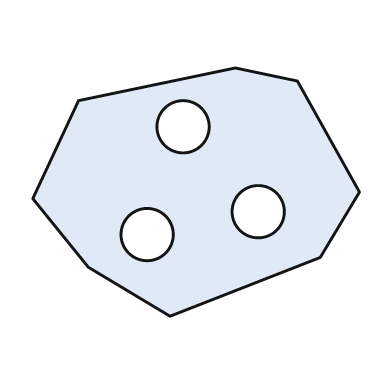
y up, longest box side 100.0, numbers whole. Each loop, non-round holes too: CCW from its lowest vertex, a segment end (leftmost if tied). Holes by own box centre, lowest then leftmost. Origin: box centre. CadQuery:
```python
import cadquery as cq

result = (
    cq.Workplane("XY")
    .moveTo(-8.0, -38.0)
    .lineTo(38.0, -20.0)
    .lineTo(50.0, 0.0)
    .lineTo(31.0, 34.0)
    .lineTo(12.0, 38.0)
    .lineTo(-36.0, 28.0)
    .lineTo(-50.0, -2.0)
    .lineTo(-33.0, -23.0)
    .close()
    .moveTo(-15.0, -13.0)
    .circle(8.0)
    .moveTo(19.0, -6.0)
    .circle(8.0)
    .moveTo(-4.0, 20.0)
    .circle(8.0)
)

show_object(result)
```